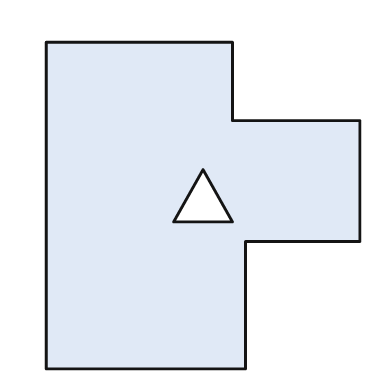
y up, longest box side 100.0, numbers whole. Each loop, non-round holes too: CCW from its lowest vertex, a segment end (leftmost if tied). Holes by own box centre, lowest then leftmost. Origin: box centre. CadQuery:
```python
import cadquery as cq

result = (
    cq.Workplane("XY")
    .moveTo(-48.0, -50.0)
    .lineTo(13.0, -50.0)
    .lineTo(13.0, -11.0)
    .lineTo(48.0, -11.0)
    .lineTo(48.0, 26.0)
    .lineTo(9.0, 26.0)
    .lineTo(9.0, 50.0)
    .lineTo(-48.0, 50.0)
    .close()
    .moveTo(-9.0, -5.0)
    .lineTo(9.0, -5.0)
    .lineTo(0.0, 11.0)
    .close()
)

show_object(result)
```